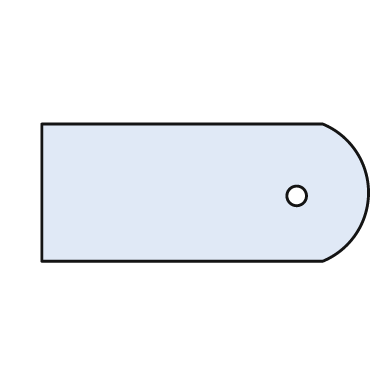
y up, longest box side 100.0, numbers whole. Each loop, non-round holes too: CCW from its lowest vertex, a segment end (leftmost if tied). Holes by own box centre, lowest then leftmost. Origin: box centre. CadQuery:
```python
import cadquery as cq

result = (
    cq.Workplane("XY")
    .moveTo(-50.0, -21.0)
    .lineTo(36.0, -21.0)
    .threePointArc((50.0, 0.0), (36.0, 21.0))
    .lineTo(-50.0, 21.0)
    .close()
    .moveTo(28.0, -1.0)
    .circle(3.0)
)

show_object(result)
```